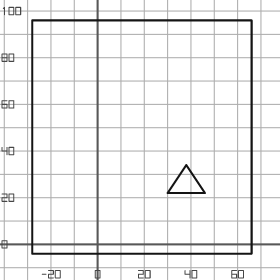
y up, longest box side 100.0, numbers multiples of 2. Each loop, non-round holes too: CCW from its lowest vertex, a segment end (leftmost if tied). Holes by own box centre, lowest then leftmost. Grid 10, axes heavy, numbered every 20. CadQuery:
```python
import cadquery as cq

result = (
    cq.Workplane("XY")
    .moveTo(-28.0, -4.0)
    .lineTo(66.0, -4.0)
    .lineTo(66.0, 96.0)
    .lineTo(-28.0, 96.0)
    .close()
    .moveTo(30.0, 22.0)
    .lineTo(46.0, 22.0)
    .lineTo(38.0, 34.0)
    .close()
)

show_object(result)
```